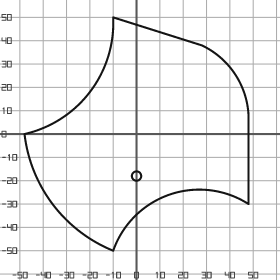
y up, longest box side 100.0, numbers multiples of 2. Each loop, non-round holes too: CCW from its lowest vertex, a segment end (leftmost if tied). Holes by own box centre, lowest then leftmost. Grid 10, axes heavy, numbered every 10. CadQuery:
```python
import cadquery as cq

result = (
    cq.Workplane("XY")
    .moveTo(-10.0, -50.0)
    .threePointArc((14.0, -26.0), (48.0, -30.0))
    .lineTo(48.0, 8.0)
    .threePointArc((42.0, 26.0), (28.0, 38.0))
    .lineTo(-10.0, 50.0)
    .threePointArc((-20.0, 18.0), (-48.0, 0.0))
    .threePointArc((-36.0, -30.0), (-10.0, -50.0))
    .close()
    .moveTo(0.0, -18.0)
    .circle(2.0)
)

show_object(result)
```